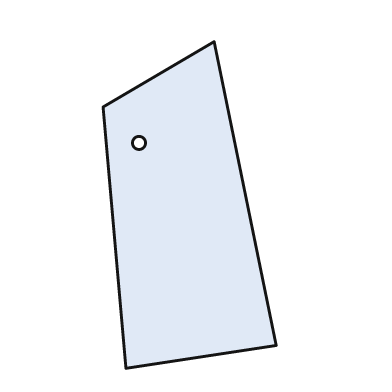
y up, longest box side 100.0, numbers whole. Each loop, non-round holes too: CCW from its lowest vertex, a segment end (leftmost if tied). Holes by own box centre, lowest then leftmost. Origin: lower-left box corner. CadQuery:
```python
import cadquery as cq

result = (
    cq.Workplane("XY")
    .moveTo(7.0, 0.0)
    .lineTo(53.0, 7.0)
    .lineTo(34.0, 100.0)
    .lineTo(0.0, 80.0)
    .close()
    .moveTo(11.0, 69.0)
    .circle(2.0)
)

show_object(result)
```